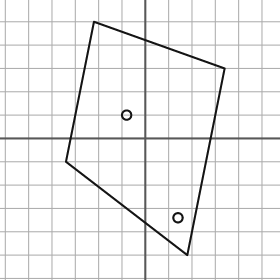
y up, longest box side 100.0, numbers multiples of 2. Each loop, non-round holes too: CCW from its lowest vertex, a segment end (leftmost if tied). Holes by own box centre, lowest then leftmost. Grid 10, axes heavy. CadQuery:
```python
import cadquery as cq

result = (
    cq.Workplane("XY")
    .moveTo(18.0, -50.0)
    .lineTo(34.0, 30.0)
    .lineTo(-22.0, 50.0)
    .lineTo(-34.0, -10.0)
    .close()
    .moveTo(14.0, -34.0)
    .circle(2.0)
    .moveTo(-8.0, 10.0)
    .circle(2.0)
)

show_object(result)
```